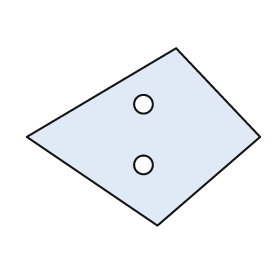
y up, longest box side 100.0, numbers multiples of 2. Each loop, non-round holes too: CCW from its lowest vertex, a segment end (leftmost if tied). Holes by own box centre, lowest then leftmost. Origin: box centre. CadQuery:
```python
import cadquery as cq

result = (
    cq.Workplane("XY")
    .moveTo(6.0, -38.0)
    .lineTo(50.0, 0.0)
    .lineTo(14.0, 38.0)
    .lineTo(-50.0, 0.0)
    .close()
    .moveTo(0.0, -12.0)
    .circle(4.0)
    .moveTo(0.0, 14.0)
    .circle(4.0)
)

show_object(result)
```